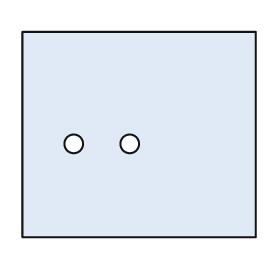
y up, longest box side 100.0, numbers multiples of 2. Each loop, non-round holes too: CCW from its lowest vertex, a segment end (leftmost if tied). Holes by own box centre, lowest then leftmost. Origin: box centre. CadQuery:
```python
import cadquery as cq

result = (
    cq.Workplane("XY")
    .moveTo(-50.0, -44.0)
    .lineTo(50.0, -44.0)
    .lineTo(50.0, 44.0)
    .lineTo(-50.0, 44.0)
    .close()
    .moveTo(-28.0, -4.0)
    .circle(4.0)
    .moveTo(-4.0, -4.0)
    .circle(4.0)
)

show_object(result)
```